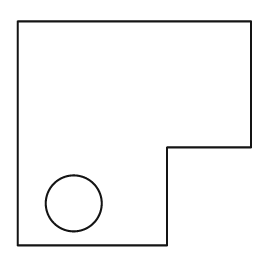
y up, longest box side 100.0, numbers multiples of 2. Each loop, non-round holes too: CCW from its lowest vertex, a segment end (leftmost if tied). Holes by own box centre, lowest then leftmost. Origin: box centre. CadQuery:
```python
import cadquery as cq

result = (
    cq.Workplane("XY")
    .moveTo(-50.0, -48.0)
    .lineTo(14.0, -48.0)
    .lineTo(14.0, -6.0)
    .lineTo(50.0, -6.0)
    .lineTo(50.0, 48.0)
    .lineTo(-50.0, 48.0)
    .close()
    .moveTo(-26.0, -30.0)
    .circle(12.0)
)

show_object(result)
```